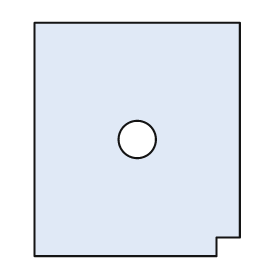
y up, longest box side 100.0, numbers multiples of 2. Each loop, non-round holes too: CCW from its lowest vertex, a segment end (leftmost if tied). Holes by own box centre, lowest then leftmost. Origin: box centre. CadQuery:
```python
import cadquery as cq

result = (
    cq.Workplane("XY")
    .moveTo(-44.0, -50.0)
    .lineTo(34.0, -50.0)
    .lineTo(34.0, -42.0)
    .lineTo(44.0, -42.0)
    .lineTo(44.0, 50.0)
    .lineTo(-44.0, 50.0)
    .close()
    .moveTo(0.0, 0.0)
    .circle(8.0)
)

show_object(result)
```